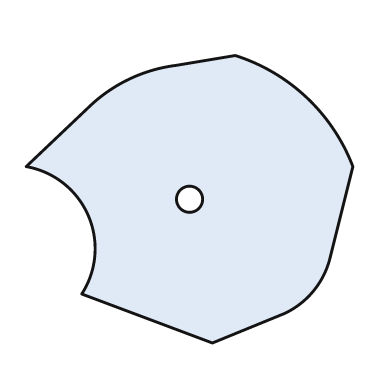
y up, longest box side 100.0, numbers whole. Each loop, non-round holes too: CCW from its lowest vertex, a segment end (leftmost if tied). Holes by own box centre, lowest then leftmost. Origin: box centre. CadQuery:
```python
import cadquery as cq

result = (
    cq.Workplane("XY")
    .moveTo(7.0, -44.0)
    .lineTo(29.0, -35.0)
    .threePointArc((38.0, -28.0), (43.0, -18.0))
    .lineTo(50.0, 10.0)
    .threePointArc((36.0, 31.0), (14.0, 44.0))
    .lineTo(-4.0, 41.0)
    .threePointArc((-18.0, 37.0), (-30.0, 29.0))
    .lineTo(-50.0, 10.0)
    .threePointArc((-31.0, -5.0), (-33.0, -29.0))
    .close()
    .moveTo(0.0, 0.0)
    .circle(4.0)
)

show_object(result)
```